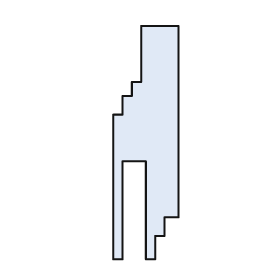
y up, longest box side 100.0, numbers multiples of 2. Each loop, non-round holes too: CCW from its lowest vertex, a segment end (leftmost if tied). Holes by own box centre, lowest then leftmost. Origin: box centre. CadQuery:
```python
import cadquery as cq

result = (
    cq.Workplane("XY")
    .moveTo(-14.0, -50.0)
    .lineTo(-10.0, -50.0)
    .lineTo(-10.0, -8.0)
    .lineTo(0.0, -8.0)
    .lineTo(0.0, -50.0)
    .lineTo(4.0, -50.0)
    .lineTo(4.0, -40.0)
    .lineTo(8.0, -40.0)
    .lineTo(8.0, -32.0)
    .lineTo(14.0, -32.0)
    .lineTo(14.0, 50.0)
    .lineTo(-2.0, 50.0)
    .lineTo(-2.0, 26.0)
    .lineTo(-6.0, 26.0)
    .lineTo(-6.0, 20.0)
    .lineTo(-10.0, 20.0)
    .lineTo(-10.0, 12.0)
    .lineTo(-14.0, 12.0)
    .close()
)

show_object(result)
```